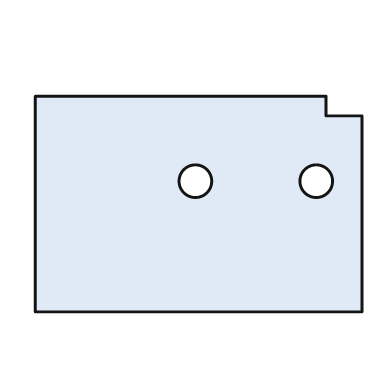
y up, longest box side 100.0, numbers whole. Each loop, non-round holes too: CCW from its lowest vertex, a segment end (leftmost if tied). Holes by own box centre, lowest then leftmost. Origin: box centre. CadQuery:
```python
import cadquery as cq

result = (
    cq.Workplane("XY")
    .moveTo(-50.0, -33.0)
    .lineTo(50.0, -33.0)
    .lineTo(50.0, 27.0)
    .lineTo(39.0, 27.0)
    .lineTo(39.0, 33.0)
    .lineTo(-50.0, 33.0)
    .close()
    .moveTo(-1.0, 7.0)
    .circle(5.0)
    .moveTo(36.0, 7.0)
    .circle(5.0)
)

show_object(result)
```